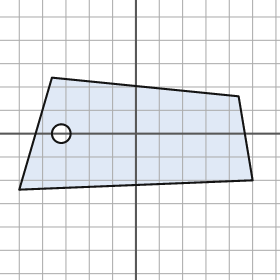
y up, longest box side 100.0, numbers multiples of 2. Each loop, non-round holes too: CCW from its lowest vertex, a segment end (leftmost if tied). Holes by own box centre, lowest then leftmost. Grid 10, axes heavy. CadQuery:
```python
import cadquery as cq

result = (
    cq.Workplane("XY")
    .moveTo(-50.0, -24.0)
    .lineTo(50.0, -20.0)
    .lineTo(44.0, 16.0)
    .lineTo(-36.0, 24.0)
    .close()
    .moveTo(-32.0, 0.0)
    .circle(4.0)
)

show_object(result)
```